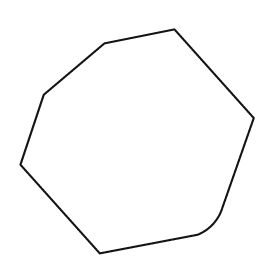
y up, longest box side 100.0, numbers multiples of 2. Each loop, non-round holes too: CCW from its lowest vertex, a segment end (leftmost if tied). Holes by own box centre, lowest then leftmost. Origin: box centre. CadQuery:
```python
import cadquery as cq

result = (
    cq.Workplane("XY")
    .moveTo(-16.0, -48.0)
    .lineTo(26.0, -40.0)
    .threePointArc((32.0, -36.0), (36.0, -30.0))
    .lineTo(50.0, 10.0)
    .lineTo(16.0, 48.0)
    .lineTo(-14.0, 42.0)
    .lineTo(-40.0, 20.0)
    .lineTo(-50.0, -10.0)
    .close()
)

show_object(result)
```